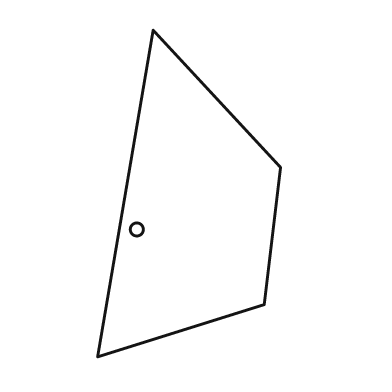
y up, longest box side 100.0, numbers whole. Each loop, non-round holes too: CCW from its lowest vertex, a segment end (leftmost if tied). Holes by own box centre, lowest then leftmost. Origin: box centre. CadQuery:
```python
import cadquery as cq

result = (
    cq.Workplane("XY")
    .moveTo(-28.0, -50.0)
    .lineTo(23.0, -34.0)
    .lineTo(28.0, 8.0)
    .lineTo(-11.0, 50.0)
    .close()
    .moveTo(-16.0, -11.0)
    .circle(2.0)
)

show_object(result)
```